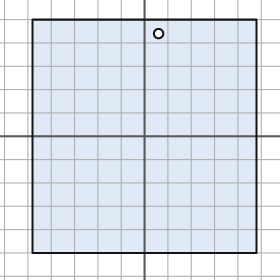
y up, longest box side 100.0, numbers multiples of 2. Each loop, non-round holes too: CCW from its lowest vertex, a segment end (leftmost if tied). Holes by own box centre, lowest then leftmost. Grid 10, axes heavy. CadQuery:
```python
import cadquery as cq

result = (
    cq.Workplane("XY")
    .moveTo(-48.0, -50.0)
    .lineTo(48.0, -50.0)
    .lineTo(48.0, 50.0)
    .lineTo(-48.0, 50.0)
    .close()
    .moveTo(6.0, 44.0)
    .circle(2.0)
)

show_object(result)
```